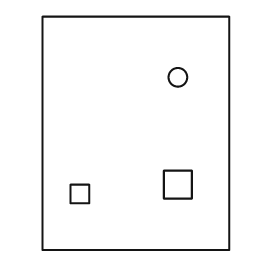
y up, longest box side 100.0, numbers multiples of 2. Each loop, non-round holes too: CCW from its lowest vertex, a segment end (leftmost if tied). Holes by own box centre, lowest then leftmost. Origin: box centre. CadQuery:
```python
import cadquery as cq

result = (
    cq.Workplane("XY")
    .moveTo(-40.0, -50.0)
    .lineTo(40.0, -50.0)
    .lineTo(40.0, 50.0)
    .lineTo(-40.0, 50.0)
    .close()
    .moveTo(-28.0, -30.0)
    .lineTo(-20.0, -30.0)
    .lineTo(-20.0, -22.0)
    .lineTo(-28.0, -22.0)
    .close()
    .moveTo(12.0, -28.0)
    .lineTo(24.0, -28.0)
    .lineTo(24.0, -16.0)
    .lineTo(12.0, -16.0)
    .close()
    .moveTo(18.0, 24.0)
    .circle(4.0)
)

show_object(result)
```